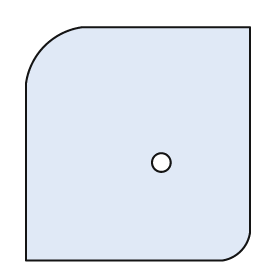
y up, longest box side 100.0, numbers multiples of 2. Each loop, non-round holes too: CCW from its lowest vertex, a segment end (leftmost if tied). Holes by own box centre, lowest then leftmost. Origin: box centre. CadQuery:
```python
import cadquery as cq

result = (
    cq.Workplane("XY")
    .moveTo(-48.0, -50.0)
    .lineTo(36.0, -50.0)
    .threePointArc((44.0, -46.0), (48.0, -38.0))
    .lineTo(48.0, 50.0)
    .lineTo(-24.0, 50.0)
    .threePointArc((-40.0, 42.0), (-48.0, 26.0))
    .close()
    .moveTo(10.0, -8.0)
    .circle(4.0)
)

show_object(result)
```